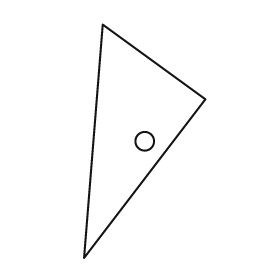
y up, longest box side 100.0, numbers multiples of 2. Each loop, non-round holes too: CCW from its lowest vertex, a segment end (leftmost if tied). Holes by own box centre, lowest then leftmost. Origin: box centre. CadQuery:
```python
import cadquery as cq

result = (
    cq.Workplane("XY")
    .moveTo(-26.0, -50.0)
    .lineTo(26.0, 18.0)
    .lineTo(-18.0, 50.0)
    .close()
    .moveTo(0.0, 0.0)
    .circle(4.0)
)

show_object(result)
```